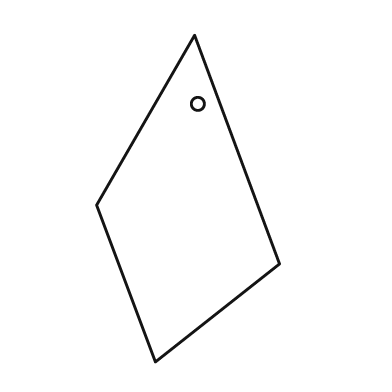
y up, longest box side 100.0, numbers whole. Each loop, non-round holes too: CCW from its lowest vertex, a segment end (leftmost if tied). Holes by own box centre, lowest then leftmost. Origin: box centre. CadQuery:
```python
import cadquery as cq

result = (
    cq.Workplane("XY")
    .moveTo(-10.0, -50.0)
    .lineTo(28.0, -20.0)
    .lineTo(2.0, 50.0)
    .lineTo(-28.0, -2.0)
    .close()
    .moveTo(3.0, 29.0)
    .circle(2.0)
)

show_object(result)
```